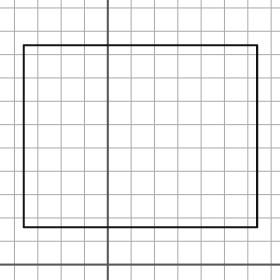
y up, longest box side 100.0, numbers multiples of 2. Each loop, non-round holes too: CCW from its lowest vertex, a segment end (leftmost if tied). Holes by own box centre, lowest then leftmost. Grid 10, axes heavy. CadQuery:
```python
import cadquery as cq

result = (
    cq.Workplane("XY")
    .moveTo(-36.0, 16.0)
    .lineTo(64.0, 16.0)
    .lineTo(64.0, 94.0)
    .lineTo(-36.0, 94.0)
    .close()
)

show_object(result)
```